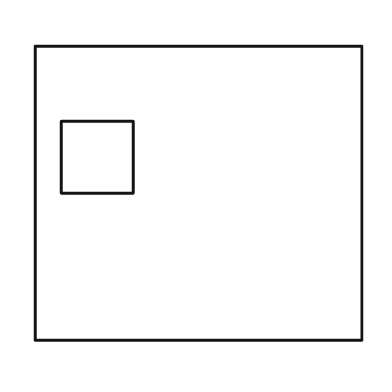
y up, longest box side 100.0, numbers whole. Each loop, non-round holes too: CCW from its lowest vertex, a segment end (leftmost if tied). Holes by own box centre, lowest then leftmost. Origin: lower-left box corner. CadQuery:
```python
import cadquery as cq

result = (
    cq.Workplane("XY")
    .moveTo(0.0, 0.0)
    .lineTo(100.0, 0.0)
    .lineTo(100.0, 90.0)
    .lineTo(0.0, 90.0)
    .close()
    .moveTo(8.0, 45.0)
    .lineTo(30.0, 45.0)
    .lineTo(30.0, 67.0)
    .lineTo(8.0, 67.0)
    .close()
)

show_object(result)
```